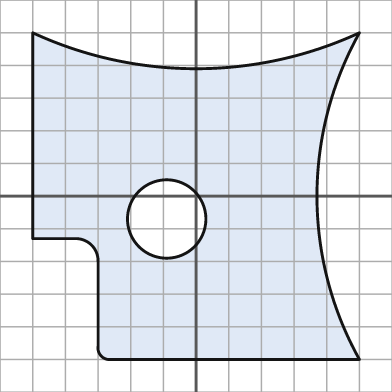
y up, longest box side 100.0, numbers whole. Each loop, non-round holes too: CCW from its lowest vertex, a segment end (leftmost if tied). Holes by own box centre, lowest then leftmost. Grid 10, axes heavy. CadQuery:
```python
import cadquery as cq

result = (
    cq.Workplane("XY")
    .moveTo(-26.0, -50.0)
    .lineTo(50.0, -50.0)
    .threePointArc((37.0, 0.0), (50.0, 50.0))
    .threePointArc((0.0, 39.0), (-50.0, 50.0))
    .lineTo(-50.0, -13.0)
    .lineTo(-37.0, -13.0)
    .threePointArc((-32.0, -15.0), (-30.0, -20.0))
    .lineTo(-30.0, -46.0)
    .threePointArc((-29.0, -49.0), (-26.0, -50.0))
    .close()
    .moveTo(-9.0, -7.0)
    .circle(12.0)
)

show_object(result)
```